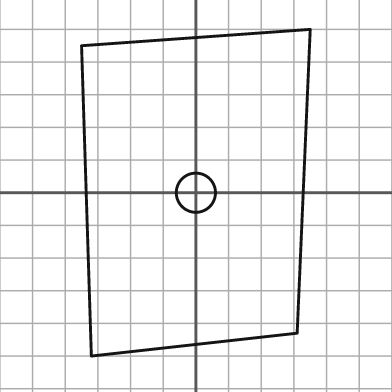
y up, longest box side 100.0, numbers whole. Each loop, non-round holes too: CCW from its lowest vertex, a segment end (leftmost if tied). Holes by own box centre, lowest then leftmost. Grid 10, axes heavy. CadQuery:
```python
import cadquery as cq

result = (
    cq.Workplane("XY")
    .moveTo(-32.0, -50.0)
    .lineTo(31.0, -43.0)
    .lineTo(35.0, 50.0)
    .lineTo(-35.0, 45.0)
    .close()
    .moveTo(0.0, 0.0)
    .circle(6.0)
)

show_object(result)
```